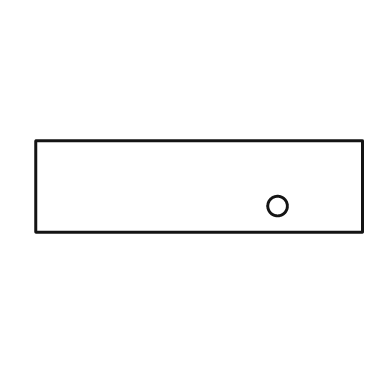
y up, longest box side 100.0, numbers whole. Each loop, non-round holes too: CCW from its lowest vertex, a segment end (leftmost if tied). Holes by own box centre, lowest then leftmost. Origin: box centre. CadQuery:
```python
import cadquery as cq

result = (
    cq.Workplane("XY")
    .moveTo(-50.0, -14.0)
    .lineTo(50.0, -14.0)
    .lineTo(50.0, 14.0)
    .lineTo(-50.0, 14.0)
    .close()
    .moveTo(24.0, -6.0)
    .circle(3.0)
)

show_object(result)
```